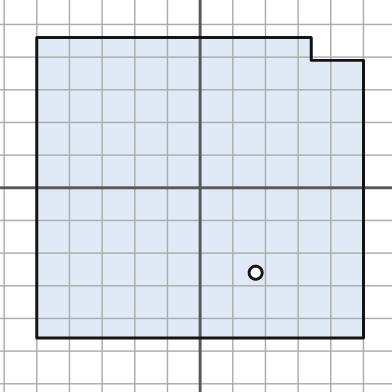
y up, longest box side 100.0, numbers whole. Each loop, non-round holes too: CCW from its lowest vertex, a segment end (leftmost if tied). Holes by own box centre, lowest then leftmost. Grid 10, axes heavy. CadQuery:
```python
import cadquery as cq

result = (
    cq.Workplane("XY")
    .moveTo(-50.0, -46.0)
    .lineTo(50.0, -46.0)
    .lineTo(50.0, 39.0)
    .lineTo(34.0, 39.0)
    .lineTo(34.0, 46.0)
    .lineTo(-50.0, 46.0)
    .close()
    .moveTo(17.0, -26.0)
    .circle(2.0)
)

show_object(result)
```